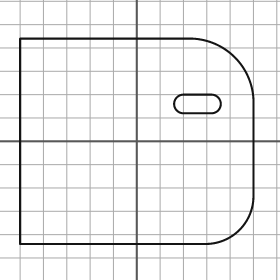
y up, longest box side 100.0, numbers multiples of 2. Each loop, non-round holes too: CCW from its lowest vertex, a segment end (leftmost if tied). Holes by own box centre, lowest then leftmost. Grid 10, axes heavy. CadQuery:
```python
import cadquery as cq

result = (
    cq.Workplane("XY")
    .moveTo(-50.0, -44.0)
    .lineTo(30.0, -44.0)
    .threePointArc((44.0, -38.0), (50.0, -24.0))
    .lineTo(50.0, 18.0)
    .threePointArc((42.0, 36.0), (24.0, 44.0))
    .lineTo(-50.0, 44.0)
    .close()
    .moveTo(20.0, 12.0)
    .lineTo(32.0, 12.0)
    .threePointArc((36.0, 16.0), (32.0, 20.0))
    .lineTo(20.0, 20.0)
    .threePointArc((16.0, 16.0), (20.0, 12.0))
    .close()
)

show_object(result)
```